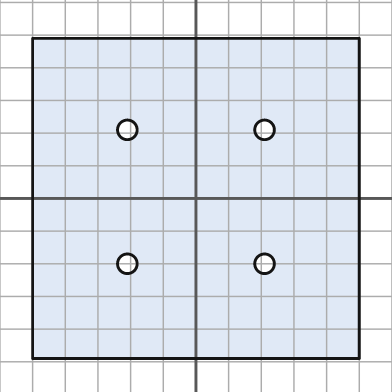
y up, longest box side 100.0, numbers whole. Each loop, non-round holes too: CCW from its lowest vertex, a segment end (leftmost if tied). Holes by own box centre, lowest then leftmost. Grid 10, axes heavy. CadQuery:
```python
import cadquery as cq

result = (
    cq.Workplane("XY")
    .moveTo(-50.0, -49.0)
    .lineTo(50.0, -49.0)
    .lineTo(50.0, 49.0)
    .lineTo(-50.0, 49.0)
    .close()
    .moveTo(-21.0, -20.0)
    .circle(3.0)
    .moveTo(21.0, -20.0)
    .circle(3.0)
    .moveTo(-21.0, 21.0)
    .circle(3.0)
    .moveTo(21.0, 21.0)
    .circle(3.0)
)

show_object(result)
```